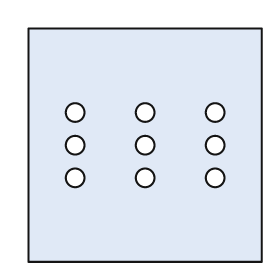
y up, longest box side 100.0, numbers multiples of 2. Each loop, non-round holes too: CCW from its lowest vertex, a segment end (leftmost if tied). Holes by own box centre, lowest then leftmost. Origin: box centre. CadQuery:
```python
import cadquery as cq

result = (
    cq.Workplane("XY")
    .moveTo(-50.0, -50.0)
    .lineTo(50.0, -50.0)
    .lineTo(50.0, 50.0)
    .lineTo(-50.0, 50.0)
    .close()
    .moveTo(-30.0, -14.0)
    .circle(4.0)
    .moveTo(0.0, -14.0)
    .circle(4.0)
    .moveTo(30.0, -14.0)
    .circle(4.0)
    .moveTo(-30.0, 0.0)
    .circle(4.0)
    .moveTo(0.0, 0.0)
    .circle(4.0)
    .moveTo(30.0, 0.0)
    .circle(4.0)
    .moveTo(-30.0, 14.0)
    .circle(4.0)
    .moveTo(0.0, 14.0)
    .circle(4.0)
    .moveTo(30.0, 14.0)
    .circle(4.0)
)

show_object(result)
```